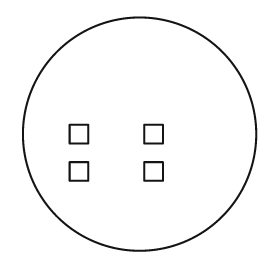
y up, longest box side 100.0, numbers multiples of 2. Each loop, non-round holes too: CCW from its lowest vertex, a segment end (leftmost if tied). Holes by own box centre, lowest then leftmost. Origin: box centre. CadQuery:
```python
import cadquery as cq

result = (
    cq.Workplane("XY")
    .moveTo(0.0, 0.0)
    .circle(50.0)
    .moveTo(-30.0, -20.0)
    .lineTo(-22.0, -20.0)
    .lineTo(-22.0, -12.0)
    .lineTo(-30.0, -12.0)
    .close()
    .moveTo(2.0, -20.0)
    .lineTo(10.0, -20.0)
    .lineTo(10.0, -12.0)
    .lineTo(2.0, -12.0)
    .close()
    .moveTo(-30.0, -4.0)
    .lineTo(-22.0, -4.0)
    .lineTo(-22.0, 4.0)
    .lineTo(-30.0, 4.0)
    .close()
    .moveTo(2.0, -4.0)
    .lineTo(10.0, -4.0)
    .lineTo(10.0, 4.0)
    .lineTo(2.0, 4.0)
    .close()
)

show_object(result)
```